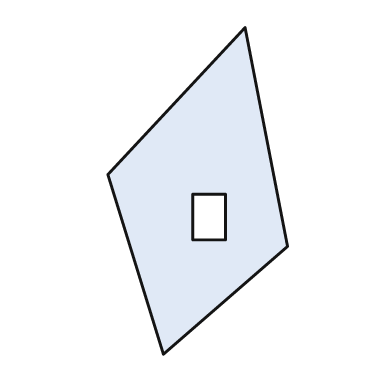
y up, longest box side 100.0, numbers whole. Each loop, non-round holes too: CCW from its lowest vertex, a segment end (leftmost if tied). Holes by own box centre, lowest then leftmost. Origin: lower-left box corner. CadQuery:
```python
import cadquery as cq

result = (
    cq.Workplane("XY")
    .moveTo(17.0, 0.0)
    .lineTo(55.0, 33.0)
    .lineTo(42.0, 100.0)
    .lineTo(0.0, 55.0)
    .close()
    .moveTo(26.0, 35.0)
    .lineTo(36.0, 35.0)
    .lineTo(36.0, 49.0)
    .lineTo(26.0, 49.0)
    .close()
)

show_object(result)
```